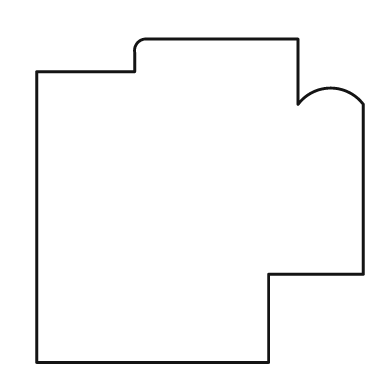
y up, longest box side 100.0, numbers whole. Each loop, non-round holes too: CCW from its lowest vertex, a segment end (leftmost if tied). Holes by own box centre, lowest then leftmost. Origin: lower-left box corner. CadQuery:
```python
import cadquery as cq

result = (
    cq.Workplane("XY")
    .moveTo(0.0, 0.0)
    .lineTo(71.0, 0.0)
    .lineTo(71.0, 27.0)
    .lineTo(100.0, 27.0)
    .lineTo(100.0, 79.0)
    .threePointArc((90.0, 84.0), (80.0, 79.0))
    .lineTo(80.0, 99.0)
    .lineTo(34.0, 99.0)
    .threePointArc((31.0, 98.0), (30.0, 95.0))
    .lineTo(30.0, 89.0)
    .lineTo(0.0, 89.0)
    .close()
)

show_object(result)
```